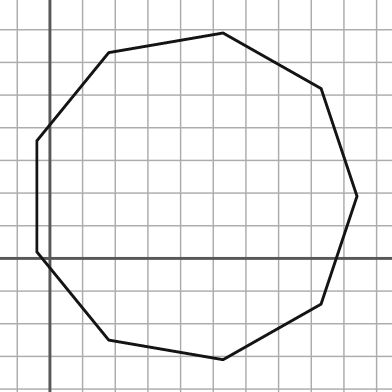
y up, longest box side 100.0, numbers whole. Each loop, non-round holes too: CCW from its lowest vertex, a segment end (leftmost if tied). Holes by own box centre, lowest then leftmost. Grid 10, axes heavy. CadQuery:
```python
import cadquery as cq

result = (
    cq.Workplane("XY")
    .moveTo(53.0, -31.0)
    .lineTo(83.0, -14.0)
    .lineTo(94.0, 19.0)
    .lineTo(83.0, 52.0)
    .lineTo(53.0, 69.0)
    .lineTo(18.0, 63.0)
    .lineTo(-4.0, 36.0)
    .lineTo(-4.0, 2.0)
    .lineTo(18.0, -25.0)
    .close()
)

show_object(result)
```